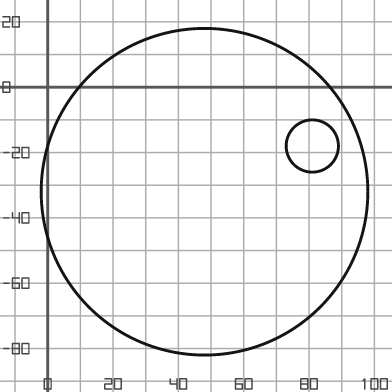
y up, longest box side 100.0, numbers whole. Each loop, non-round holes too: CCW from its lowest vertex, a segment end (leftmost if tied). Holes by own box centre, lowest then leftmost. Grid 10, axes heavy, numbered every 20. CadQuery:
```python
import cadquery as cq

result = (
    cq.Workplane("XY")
    .moveTo(48.0, -32.0)
    .circle(50.0)
    .moveTo(81.0, -18.0)
    .circle(8.0)
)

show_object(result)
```